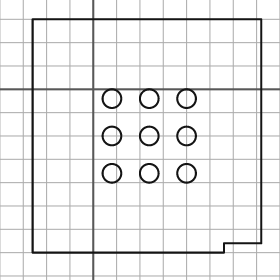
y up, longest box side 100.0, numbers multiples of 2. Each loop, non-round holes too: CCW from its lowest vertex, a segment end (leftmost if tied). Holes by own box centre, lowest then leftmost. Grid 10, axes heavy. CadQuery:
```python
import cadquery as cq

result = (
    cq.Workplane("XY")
    .moveTo(-26.0, -70.0)
    .lineTo(56.0, -70.0)
    .lineTo(56.0, -66.0)
    .lineTo(72.0, -66.0)
    .lineTo(72.0, 30.0)
    .lineTo(-26.0, 30.0)
    .close()
    .moveTo(8.0, -36.0)
    .circle(4.0)
    .moveTo(24.0, -36.0)
    .circle(4.0)
    .moveTo(40.0, -36.0)
    .circle(4.0)
    .moveTo(8.0, -20.0)
    .circle(4.0)
    .moveTo(24.0, -20.0)
    .circle(4.0)
    .moveTo(40.0, -20.0)
    .circle(4.0)
    .moveTo(8.0, -4.0)
    .circle(4.0)
    .moveTo(24.0, -4.0)
    .circle(4.0)
    .moveTo(40.0, -4.0)
    .circle(4.0)
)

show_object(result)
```